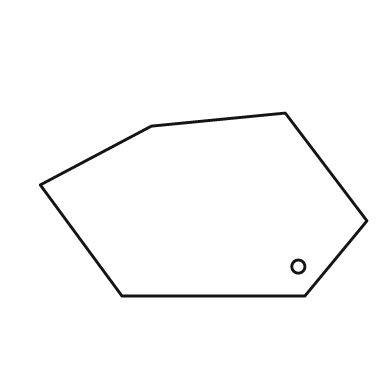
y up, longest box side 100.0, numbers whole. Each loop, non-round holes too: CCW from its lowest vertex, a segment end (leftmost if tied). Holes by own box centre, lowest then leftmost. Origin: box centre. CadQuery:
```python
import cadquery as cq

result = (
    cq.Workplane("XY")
    .moveTo(-25.0, -28.0)
    .lineTo(31.0, -28.0)
    .lineTo(50.0, -5.0)
    .lineTo(25.0, 28.0)
    .lineTo(-16.0, 24.0)
    .lineTo(-50.0, 6.0)
    .close()
    .moveTo(29.0, -19.0)
    .circle(2.0)
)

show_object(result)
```